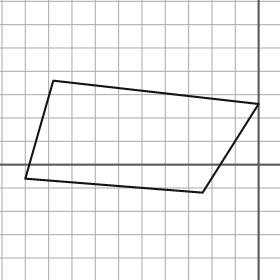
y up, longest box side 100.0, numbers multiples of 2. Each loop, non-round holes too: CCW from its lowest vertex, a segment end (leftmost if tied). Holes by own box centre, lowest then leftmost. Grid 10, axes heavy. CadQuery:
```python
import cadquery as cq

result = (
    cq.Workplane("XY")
    .moveTo(-24.0, -12.0)
    .lineTo(0.0, 26.0)
    .lineTo(-88.0, 36.0)
    .lineTo(-100.0, -6.0)
    .close()
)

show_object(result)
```